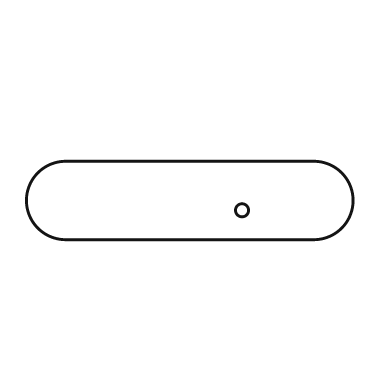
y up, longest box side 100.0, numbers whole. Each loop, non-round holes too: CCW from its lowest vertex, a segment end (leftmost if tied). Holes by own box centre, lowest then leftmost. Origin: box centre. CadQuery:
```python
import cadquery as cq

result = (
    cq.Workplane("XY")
    .moveTo(-38.0, -12.0)
    .lineTo(38.0, -12.0)
    .threePointArc((50.0, 0.0), (38.0, 12.0))
    .lineTo(-38.0, 12.0)
    .threePointArc((-50.0, 0.0), (-38.0, -12.0))
    .close()
    .moveTo(16.0, -3.0)
    .circle(2.0)
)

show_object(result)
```